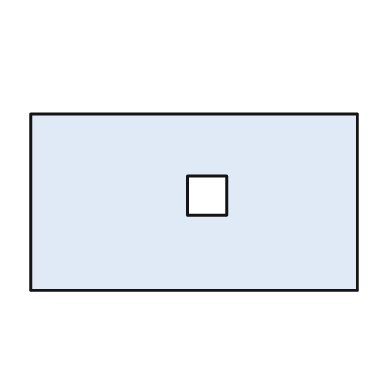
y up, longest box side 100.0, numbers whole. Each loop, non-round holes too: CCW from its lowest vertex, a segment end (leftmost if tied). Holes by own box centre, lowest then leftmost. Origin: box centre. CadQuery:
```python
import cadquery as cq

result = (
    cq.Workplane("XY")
    .moveTo(-50.0, -27.0)
    .lineTo(50.0, -27.0)
    .lineTo(50.0, 27.0)
    .lineTo(-50.0, 27.0)
    .close()
    .moveTo(-2.0, -4.0)
    .lineTo(10.0, -4.0)
    .lineTo(10.0, 8.0)
    .lineTo(-2.0, 8.0)
    .close()
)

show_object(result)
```